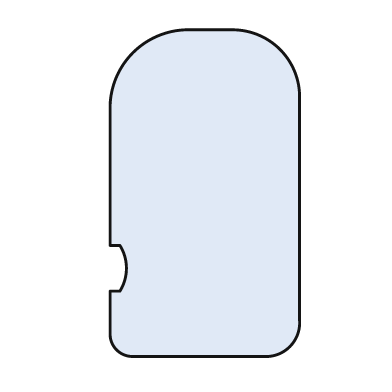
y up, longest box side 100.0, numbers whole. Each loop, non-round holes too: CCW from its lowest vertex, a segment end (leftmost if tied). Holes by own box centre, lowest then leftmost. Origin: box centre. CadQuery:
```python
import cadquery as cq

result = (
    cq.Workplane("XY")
    .moveTo(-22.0, -50.0)
    .lineTo(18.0, -50.0)
    .threePointArc((26.0, -47.0), (29.0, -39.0))
    .lineTo(29.0, 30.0)
    .threePointArc((23.0, 44.0), (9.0, 50.0))
    .lineTo(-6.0, 50.0)
    .threePointArc((-22.0, 43.0), (-29.0, 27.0))
    .lineTo(-29.0, -16.0)
    .lineTo(-26.0, -16.0)
    .threePointArc((-24.0, -23.0), (-26.0, -30.0))
    .lineTo(-29.0, -30.0)
    .lineTo(-29.0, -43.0)
    .threePointArc((-27.0, -48.0), (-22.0, -50.0))
    .close()
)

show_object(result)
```